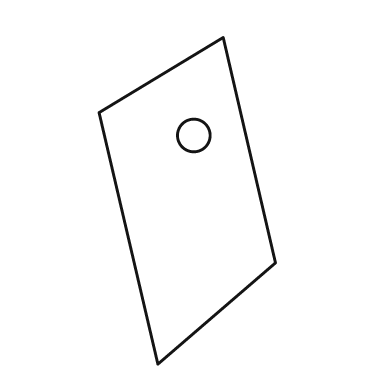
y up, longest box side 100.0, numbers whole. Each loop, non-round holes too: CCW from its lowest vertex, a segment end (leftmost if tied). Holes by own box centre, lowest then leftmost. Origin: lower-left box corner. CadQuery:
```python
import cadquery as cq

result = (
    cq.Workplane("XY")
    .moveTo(18.0, 0.0)
    .lineTo(54.0, 31.0)
    .lineTo(38.0, 100.0)
    .lineTo(0.0, 77.0)
    .close()
    .moveTo(29.0, 70.0)
    .circle(5.0)
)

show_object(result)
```